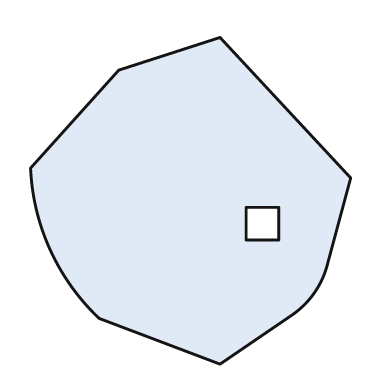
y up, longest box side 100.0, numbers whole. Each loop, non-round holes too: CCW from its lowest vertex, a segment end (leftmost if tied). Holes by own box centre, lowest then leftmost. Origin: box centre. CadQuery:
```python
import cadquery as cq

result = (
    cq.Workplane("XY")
    .moveTo(9.0, -50.0)
    .lineTo(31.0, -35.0)
    .threePointArc((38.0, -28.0), (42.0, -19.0))
    .lineTo(49.0, 7.0)
    .lineTo(9.0, 50.0)
    .lineTo(-22.0, 40.0)
    .lineTo(-49.0, 10.0)
    .threePointArc((-43.0, -15.0), (-28.0, -36.0))
    .close()
    .moveTo(17.0, -12.0)
    .lineTo(27.0, -12.0)
    .lineTo(27.0, -2.0)
    .lineTo(17.0, -2.0)
    .close()
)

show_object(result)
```